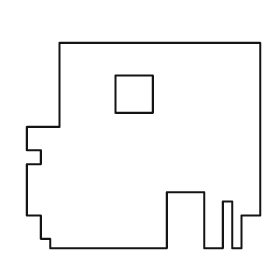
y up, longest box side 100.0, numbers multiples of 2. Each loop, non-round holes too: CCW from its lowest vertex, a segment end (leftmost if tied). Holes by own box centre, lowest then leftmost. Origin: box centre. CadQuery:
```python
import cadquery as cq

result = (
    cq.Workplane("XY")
    .moveTo(-40.0, -44.0)
    .lineTo(10.0, -44.0)
    .lineTo(10.0, -20.0)
    .lineTo(26.0, -20.0)
    .lineTo(26.0, -44.0)
    .lineTo(34.0, -44.0)
    .lineTo(34.0, -24.0)
    .lineTo(38.0, -24.0)
    .lineTo(38.0, -44.0)
    .lineTo(42.0, -44.0)
    .lineTo(42.0, -30.0)
    .lineTo(50.0, -30.0)
    .lineTo(50.0, 44.0)
    .lineTo(-36.0, 44.0)
    .lineTo(-36.0, 8.0)
    .lineTo(-50.0, 8.0)
    .lineTo(-50.0, -2.0)
    .lineTo(-44.0, -2.0)
    .lineTo(-44.0, -8.0)
    .lineTo(-50.0, -8.0)
    .lineTo(-50.0, -30.0)
    .lineTo(-44.0, -30.0)
    .lineTo(-44.0, -40.0)
    .lineTo(-40.0, -40.0)
    .close()
    .moveTo(-12.0, 14.0)
    .lineTo(4.0, 14.0)
    .lineTo(4.0, 30.0)
    .lineTo(-12.0, 30.0)
    .close()
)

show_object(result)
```